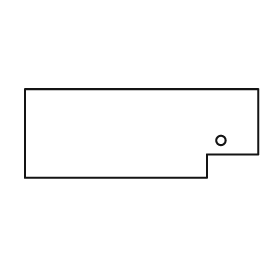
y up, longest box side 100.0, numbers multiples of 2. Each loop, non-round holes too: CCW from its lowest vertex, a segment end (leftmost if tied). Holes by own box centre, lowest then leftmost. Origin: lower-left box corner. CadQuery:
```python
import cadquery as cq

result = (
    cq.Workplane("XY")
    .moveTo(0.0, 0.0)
    .lineTo(78.0, 0.0)
    .lineTo(78.0, 10.0)
    .lineTo(100.0, 10.0)
    .lineTo(100.0, 38.0)
    .lineTo(0.0, 38.0)
    .close()
    .moveTo(84.0, 16.0)
    .circle(2.0)
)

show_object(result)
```